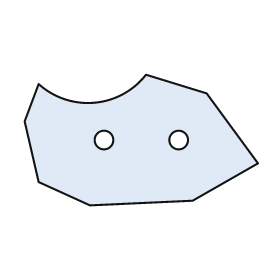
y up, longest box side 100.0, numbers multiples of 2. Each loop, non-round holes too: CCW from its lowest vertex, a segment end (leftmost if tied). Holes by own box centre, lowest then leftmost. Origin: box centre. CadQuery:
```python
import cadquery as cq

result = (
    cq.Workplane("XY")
    .moveTo(-22.0, -28.0)
    .lineTo(22.0, -26.0)
    .lineTo(50.0, -10.0)
    .lineTo(28.0, 20.0)
    .lineTo(2.0, 28.0)
    .threePointArc((-20.0, 16.0), (-44.0, 24.0))
    .lineTo(-50.0, 8.0)
    .lineTo(-44.0, -18.0)
    .close()
    .moveTo(-16.0, 0.0)
    .circle(4.0)
    .moveTo(16.0, 0.0)
    .circle(4.0)
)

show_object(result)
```